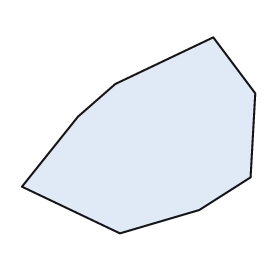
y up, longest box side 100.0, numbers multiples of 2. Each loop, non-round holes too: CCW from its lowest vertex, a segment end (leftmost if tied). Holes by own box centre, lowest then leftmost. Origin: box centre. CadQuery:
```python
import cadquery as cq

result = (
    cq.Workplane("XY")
    .moveTo(-8.0, -42.0)
    .lineTo(26.0, -32.0)
    .lineTo(48.0, -18.0)
    .lineTo(50.0, 18.0)
    .lineTo(32.0, 42.0)
    .lineTo(-10.0, 22.0)
    .lineTo(-26.0, 8.0)
    .lineTo(-50.0, -22.0)
    .close()
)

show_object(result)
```